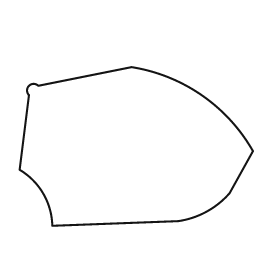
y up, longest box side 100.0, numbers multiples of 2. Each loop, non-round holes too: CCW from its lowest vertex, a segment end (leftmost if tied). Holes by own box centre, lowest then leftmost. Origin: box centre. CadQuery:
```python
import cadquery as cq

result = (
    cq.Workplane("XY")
    .moveTo(-36.0, -34.0)
    .lineTo(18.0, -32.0)
    .threePointArc((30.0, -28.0), (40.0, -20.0))
    .lineTo(50.0, -2.0)
    .threePointArc((28.0, 22.0), (-2.0, 34.0))
    .lineTo(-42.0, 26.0)
    .threePointArc((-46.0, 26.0), (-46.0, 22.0))
    .lineTo(-50.0, -10.0)
    .threePointArc((-40.0, -20.0), (-36.0, -34.0))
    .close()
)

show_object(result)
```